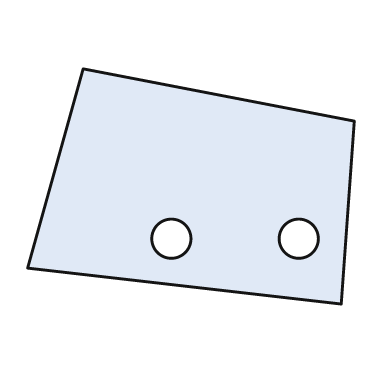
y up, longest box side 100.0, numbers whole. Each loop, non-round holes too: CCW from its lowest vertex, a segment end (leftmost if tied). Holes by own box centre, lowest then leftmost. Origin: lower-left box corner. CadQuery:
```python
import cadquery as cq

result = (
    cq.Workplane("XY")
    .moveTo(96.0, 0.0)
    .lineTo(100.0, 56.0)
    .lineTo(17.0, 72.0)
    .lineTo(0.0, 11.0)
    .close()
    .moveTo(44.0, 20.0)
    .circle(6.0)
    .moveTo(83.0, 20.0)
    .circle(6.0)
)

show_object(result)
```